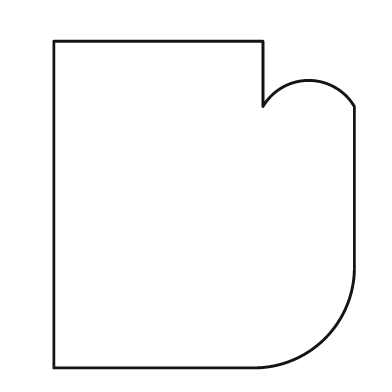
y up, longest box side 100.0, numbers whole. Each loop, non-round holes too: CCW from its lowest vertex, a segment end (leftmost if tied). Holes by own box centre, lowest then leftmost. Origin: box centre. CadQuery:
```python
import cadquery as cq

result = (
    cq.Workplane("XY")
    .moveTo(-46.0, -50.0)
    .lineTo(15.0, -50.0)
    .threePointArc((37.0, -41.0), (46.0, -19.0))
    .lineTo(46.0, 30.0)
    .threePointArc((32.0, 38.0), (18.0, 30.0))
    .lineTo(18.0, 50.0)
    .lineTo(-46.0, 50.0)
    .close()
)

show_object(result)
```